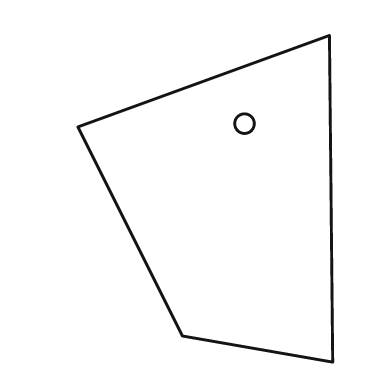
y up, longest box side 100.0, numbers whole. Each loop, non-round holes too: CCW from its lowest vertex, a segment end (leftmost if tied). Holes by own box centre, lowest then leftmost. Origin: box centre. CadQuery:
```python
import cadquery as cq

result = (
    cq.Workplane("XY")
    .moveTo(39.0, -50.0)
    .lineTo(38.0, 50.0)
    .lineTo(-39.0, 22.0)
    .lineTo(-7.0, -42.0)
    .close()
    .moveTo(12.0, 23.0)
    .circle(3.0)
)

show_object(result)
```